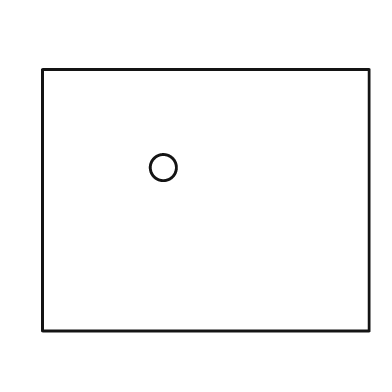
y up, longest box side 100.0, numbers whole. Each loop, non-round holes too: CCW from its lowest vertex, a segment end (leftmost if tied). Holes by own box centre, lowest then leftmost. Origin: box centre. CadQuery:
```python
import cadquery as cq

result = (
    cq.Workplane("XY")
    .moveTo(-50.0, -40.0)
    .lineTo(50.0, -40.0)
    .lineTo(50.0, 40.0)
    .lineTo(-50.0, 40.0)
    .close()
    .moveTo(-13.0, 10.0)
    .circle(4.0)
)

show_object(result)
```